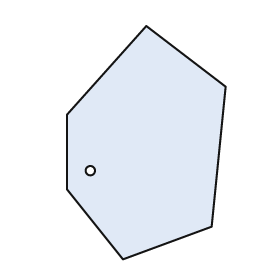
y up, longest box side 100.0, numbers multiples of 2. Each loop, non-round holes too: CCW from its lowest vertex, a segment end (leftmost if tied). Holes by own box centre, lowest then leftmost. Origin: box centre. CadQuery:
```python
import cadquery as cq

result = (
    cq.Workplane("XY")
    .moveTo(-10.0, -50.0)
    .lineTo(28.0, -36.0)
    .lineTo(34.0, 24.0)
    .lineTo(0.0, 50.0)
    .lineTo(-34.0, 12.0)
    .lineTo(-34.0, -20.0)
    .close()
    .moveTo(-24.0, -12.0)
    .circle(2.0)
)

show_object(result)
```